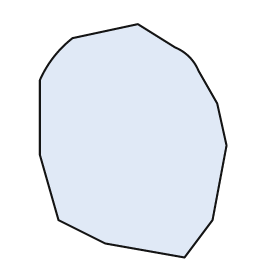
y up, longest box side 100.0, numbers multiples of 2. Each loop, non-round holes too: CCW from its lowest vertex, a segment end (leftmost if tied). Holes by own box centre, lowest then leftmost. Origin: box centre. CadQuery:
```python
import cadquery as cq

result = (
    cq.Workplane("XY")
    .moveTo(22.0, -50.0)
    .lineTo(34.0, -34.0)
    .lineTo(40.0, -2.0)
    .lineTo(36.0, 16.0)
    .lineTo(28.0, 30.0)
    .threePointArc((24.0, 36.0), (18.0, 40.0))
    .lineTo(2.0, 50.0)
    .lineTo(-26.0, 44.0)
    .threePointArc((-34.0, 36.0), (-40.0, 26.0))
    .lineTo(-40.0, -6.0)
    .lineTo(-32.0, -34.0)
    .lineTo(-12.0, -44.0)
    .close()
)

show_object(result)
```